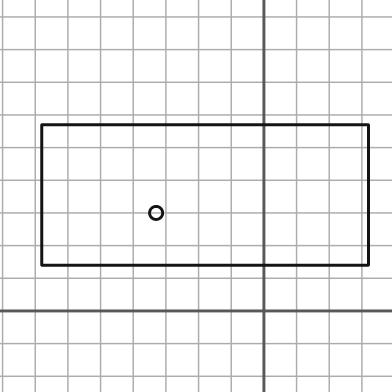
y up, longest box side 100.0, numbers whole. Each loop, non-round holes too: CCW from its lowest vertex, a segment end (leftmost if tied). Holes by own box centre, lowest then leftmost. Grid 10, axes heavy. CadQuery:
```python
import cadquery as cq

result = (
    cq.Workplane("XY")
    .moveTo(-68.0, 14.0)
    .lineTo(32.0, 14.0)
    .lineTo(32.0, 57.0)
    .lineTo(-68.0, 57.0)
    .close()
    .moveTo(-33.0, 30.0)
    .circle(2.0)
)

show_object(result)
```